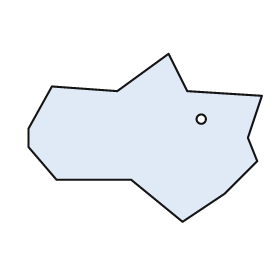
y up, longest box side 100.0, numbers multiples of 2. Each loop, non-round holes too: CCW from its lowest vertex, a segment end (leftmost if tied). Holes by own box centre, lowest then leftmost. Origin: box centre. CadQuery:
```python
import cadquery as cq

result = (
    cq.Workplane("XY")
    .moveTo(16.0, -36.0)
    .lineTo(34.0, -24.0)
    .lineTo(48.0, -10.0)
    .lineTo(44.0, 0.0)
    .lineTo(50.0, 18.0)
    .lineTo(18.0, 20.0)
    .lineTo(10.0, 36.0)
    .lineTo(-12.0, 20.0)
    .lineTo(-40.0, 22.0)
    .lineTo(-50.0, 4.0)
    .lineTo(-50.0, -4.0)
    .lineTo(-38.0, -18.0)
    .lineTo(-6.0, -18.0)
    .close()
    .moveTo(24.0, 8.0)
    .circle(2.0)
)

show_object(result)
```